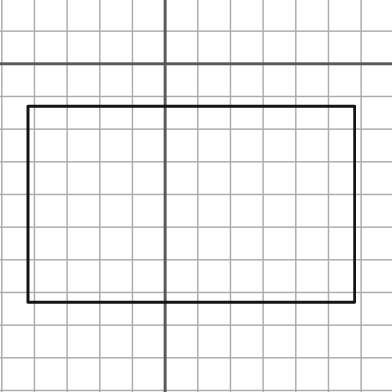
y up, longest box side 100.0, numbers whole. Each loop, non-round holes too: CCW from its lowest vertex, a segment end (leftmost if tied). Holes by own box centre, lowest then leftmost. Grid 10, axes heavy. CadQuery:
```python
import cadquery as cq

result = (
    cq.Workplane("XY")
    .moveTo(-42.0, -73.0)
    .lineTo(58.0, -73.0)
    .lineTo(58.0, -13.0)
    .lineTo(-42.0, -13.0)
    .close()
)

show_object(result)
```